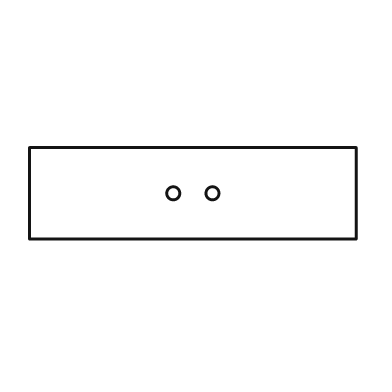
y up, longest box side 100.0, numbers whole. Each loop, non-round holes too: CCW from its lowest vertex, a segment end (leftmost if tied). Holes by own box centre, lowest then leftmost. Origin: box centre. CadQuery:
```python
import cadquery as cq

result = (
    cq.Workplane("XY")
    .moveTo(-50.0, -14.0)
    .lineTo(50.0, -14.0)
    .lineTo(50.0, 14.0)
    .lineTo(-50.0, 14.0)
    .close()
    .moveTo(-6.0, 0.0)
    .circle(2.0)
    .moveTo(6.0, 0.0)
    .circle(2.0)
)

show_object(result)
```